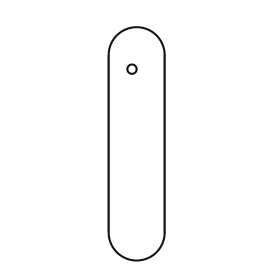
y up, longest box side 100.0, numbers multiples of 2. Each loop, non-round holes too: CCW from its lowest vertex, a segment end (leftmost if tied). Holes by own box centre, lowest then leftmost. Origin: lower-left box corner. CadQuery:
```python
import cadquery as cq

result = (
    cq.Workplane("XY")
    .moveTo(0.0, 12.0)
    .threePointArc((12.0, 0.0), (24.0, 12.0))
    .lineTo(24.0, 88.0)
    .threePointArc((12.0, 100.0), (0.0, 88.0))
    .close()
    .moveTo(10.0, 82.0)
    .circle(2.0)
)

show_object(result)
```